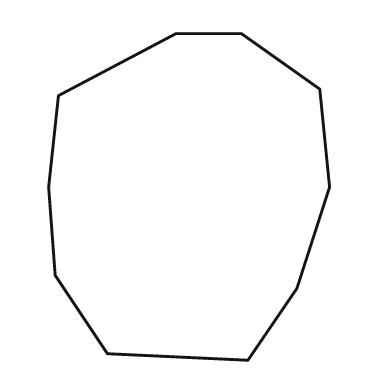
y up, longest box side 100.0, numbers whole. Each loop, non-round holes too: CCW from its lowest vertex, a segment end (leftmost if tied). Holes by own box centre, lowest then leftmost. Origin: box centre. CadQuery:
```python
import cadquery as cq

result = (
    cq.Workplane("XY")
    .moveTo(18.0, -50.0)
    .lineTo(33.0, -28.0)
    .lineTo(43.0, 3.0)
    .lineTo(40.0, 33.0)
    .lineTo(16.0, 50.0)
    .lineTo(-4.0, 50.0)
    .lineTo(-40.0, 31.0)
    .lineTo(-43.0, 3.0)
    .lineTo(-41.0, -24.0)
    .lineTo(-25.0, -48.0)
    .close()
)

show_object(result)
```